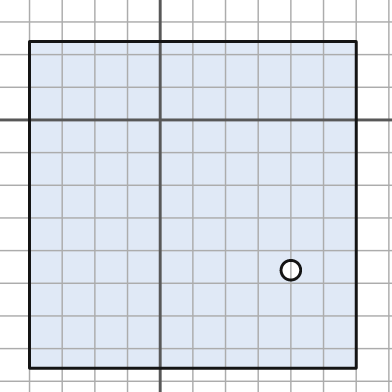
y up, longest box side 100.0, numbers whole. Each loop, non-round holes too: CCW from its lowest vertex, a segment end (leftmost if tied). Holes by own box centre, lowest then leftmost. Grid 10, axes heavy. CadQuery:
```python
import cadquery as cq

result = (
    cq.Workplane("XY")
    .moveTo(-40.0, -76.0)
    .lineTo(60.0, -76.0)
    .lineTo(60.0, 24.0)
    .lineTo(-40.0, 24.0)
    .close()
    .moveTo(40.0, -46.0)
    .circle(3.0)
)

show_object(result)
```